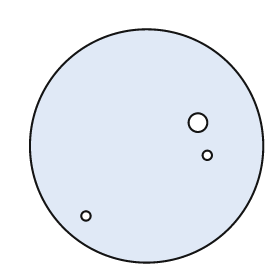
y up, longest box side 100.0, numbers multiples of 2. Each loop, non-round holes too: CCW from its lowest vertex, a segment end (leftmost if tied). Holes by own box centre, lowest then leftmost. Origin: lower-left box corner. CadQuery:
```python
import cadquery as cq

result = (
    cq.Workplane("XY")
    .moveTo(50.0, 50.0)
    .circle(50.0)
    .moveTo(24.0, 20.0)
    .circle(2.0)
    .moveTo(76.0, 46.0)
    .circle(2.0)
    .moveTo(72.0, 60.0)
    .circle(4.0)
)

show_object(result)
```